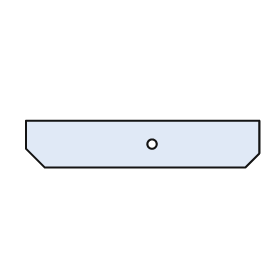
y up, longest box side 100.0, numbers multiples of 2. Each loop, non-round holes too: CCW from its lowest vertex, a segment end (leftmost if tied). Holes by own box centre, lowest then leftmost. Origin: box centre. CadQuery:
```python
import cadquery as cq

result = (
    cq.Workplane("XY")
    .moveTo(-42.0, -10.0)
    .lineTo(44.0, -10.0)
    .lineTo(50.0, -4.0)
    .lineTo(50.0, 10.0)
    .lineTo(-50.0, 10.0)
    .lineTo(-50.0, -2.0)
    .close()
    .moveTo(4.0, 0.0)
    .circle(2.0)
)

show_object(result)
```